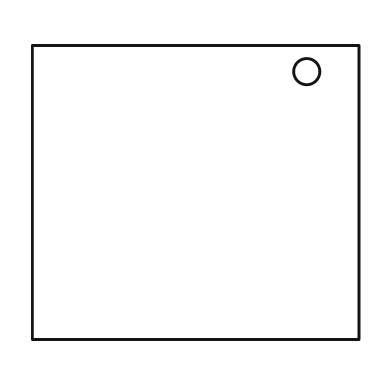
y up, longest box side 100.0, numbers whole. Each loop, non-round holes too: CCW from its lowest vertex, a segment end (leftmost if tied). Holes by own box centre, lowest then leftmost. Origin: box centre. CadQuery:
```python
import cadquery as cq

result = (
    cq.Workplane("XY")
    .moveTo(-50.0, -45.0)
    .lineTo(50.0, -45.0)
    .lineTo(50.0, 45.0)
    .lineTo(-50.0, 45.0)
    .close()
    .moveTo(34.0, 37.0)
    .circle(4.0)
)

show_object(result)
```